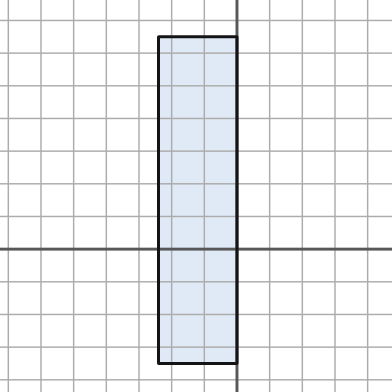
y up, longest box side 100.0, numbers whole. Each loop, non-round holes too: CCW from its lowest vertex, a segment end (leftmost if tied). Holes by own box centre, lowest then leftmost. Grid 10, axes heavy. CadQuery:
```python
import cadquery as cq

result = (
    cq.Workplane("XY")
    .moveTo(-24.0, -35.0)
    .lineTo(0.0, -35.0)
    .lineTo(0.0, 65.0)
    .lineTo(-24.0, 65.0)
    .close()
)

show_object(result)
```